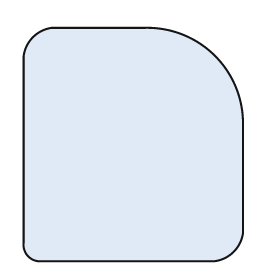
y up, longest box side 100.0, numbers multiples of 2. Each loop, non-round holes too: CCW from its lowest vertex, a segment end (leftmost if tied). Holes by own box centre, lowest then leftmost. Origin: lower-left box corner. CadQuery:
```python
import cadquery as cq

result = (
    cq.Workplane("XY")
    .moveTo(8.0, 0.0)
    .lineTo(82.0, 0.0)
    .threePointArc((90.0, 4.0), (94.0, 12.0))
    .lineTo(94.0, 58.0)
    .threePointArc((82.0, 88.0), (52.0, 100.0))
    .lineTo(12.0, 100.0)
    .threePointArc((4.0, 96.0), (0.0, 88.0))
    .lineTo(0.0, 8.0)
    .threePointArc((2.0, 2.0), (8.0, 0.0))
    .close()
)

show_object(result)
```